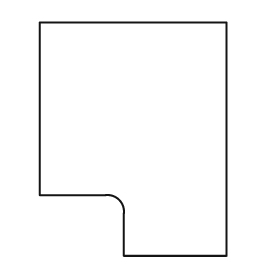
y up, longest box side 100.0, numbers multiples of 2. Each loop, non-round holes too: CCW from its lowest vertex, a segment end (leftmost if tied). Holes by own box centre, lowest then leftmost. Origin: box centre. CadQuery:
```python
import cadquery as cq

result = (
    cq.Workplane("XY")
    .moveTo(-4.0, -50.0)
    .lineTo(40.0, -50.0)
    .lineTo(40.0, 50.0)
    .lineTo(-40.0, 50.0)
    .lineTo(-40.0, -24.0)
    .lineTo(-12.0, -24.0)
    .threePointArc((-6.0, -26.0), (-4.0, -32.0))
    .close()
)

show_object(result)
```